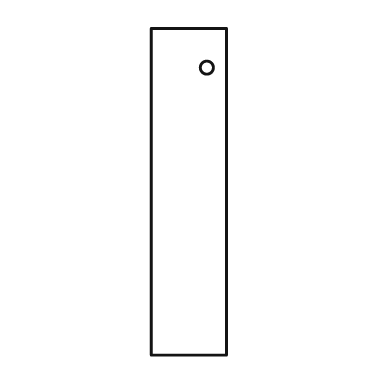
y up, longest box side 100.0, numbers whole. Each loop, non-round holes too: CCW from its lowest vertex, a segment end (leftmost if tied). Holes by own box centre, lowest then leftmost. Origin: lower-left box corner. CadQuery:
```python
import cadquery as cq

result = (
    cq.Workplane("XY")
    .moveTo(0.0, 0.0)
    .lineTo(23.0, 0.0)
    .lineTo(23.0, 100.0)
    .lineTo(0.0, 100.0)
    .close()
    .moveTo(17.0, 88.0)
    .circle(2.0)
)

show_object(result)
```